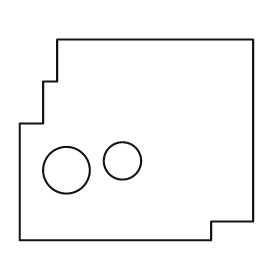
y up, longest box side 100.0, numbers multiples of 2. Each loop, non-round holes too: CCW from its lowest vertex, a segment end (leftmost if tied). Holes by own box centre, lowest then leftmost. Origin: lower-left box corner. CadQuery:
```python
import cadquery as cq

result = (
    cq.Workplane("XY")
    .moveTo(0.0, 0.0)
    .lineTo(82.0, 0.0)
    .lineTo(82.0, 8.0)
    .lineTo(100.0, 8.0)
    .lineTo(100.0, 86.0)
    .lineTo(16.0, 86.0)
    .lineTo(16.0, 68.0)
    .lineTo(10.0, 68.0)
    .lineTo(10.0, 50.0)
    .lineTo(0.0, 50.0)
    .close()
    .moveTo(20.0, 30.0)
    .circle(10.0)
    .moveTo(44.0, 34.0)
    .circle(8.0)
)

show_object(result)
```